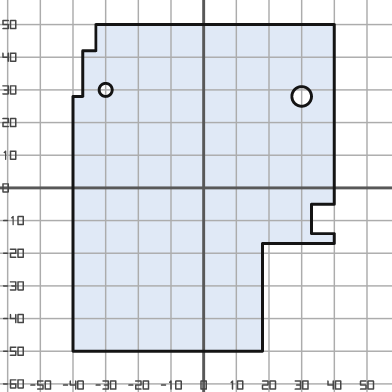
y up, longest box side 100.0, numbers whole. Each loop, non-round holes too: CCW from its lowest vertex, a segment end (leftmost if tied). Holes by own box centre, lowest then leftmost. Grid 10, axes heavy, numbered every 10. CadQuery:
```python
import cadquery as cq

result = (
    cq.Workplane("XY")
    .moveTo(-40.0, -50.0)
    .lineTo(18.0, -50.0)
    .lineTo(18.0, -17.0)
    .lineTo(40.0, -17.0)
    .lineTo(40.0, -14.0)
    .lineTo(33.0, -14.0)
    .lineTo(33.0, -5.0)
    .lineTo(40.0, -5.0)
    .lineTo(40.0, 50.0)
    .lineTo(-33.0, 50.0)
    .lineTo(-33.0, 42.0)
    .lineTo(-37.0, 42.0)
    .lineTo(-37.0, 28.0)
    .lineTo(-40.0, 28.0)
    .close()
    .moveTo(30.0, 28.0)
    .circle(3.0)
    .moveTo(-30.0, 30.0)
    .circle(2.0)
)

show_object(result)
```